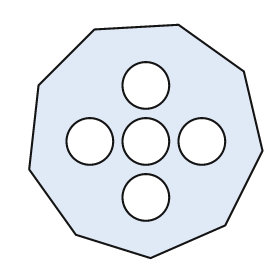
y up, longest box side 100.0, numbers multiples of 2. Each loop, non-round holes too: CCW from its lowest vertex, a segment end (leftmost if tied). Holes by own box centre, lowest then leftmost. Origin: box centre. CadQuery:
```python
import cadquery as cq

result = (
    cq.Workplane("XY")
    .moveTo(2.0, -50.0)
    .lineTo(34.0, -36.0)
    .lineTo(50.0, -4.0)
    .lineTo(42.0, 30.0)
    .lineTo(14.0, 50.0)
    .lineTo(-22.0, 48.0)
    .lineTo(-46.0, 24.0)
    .lineTo(-50.0, -12.0)
    .lineTo(-30.0, -40.0)
    .close()
    .moveTo(0.0, -24.0)
    .circle(10.0)
    .moveTo(-24.0, 0.0)
    .circle(10.0)
    .moveTo(0.0, 0.0)
    .circle(10.0)
    .moveTo(24.0, 0.0)
    .circle(10.0)
    .moveTo(0.0, 24.0)
    .circle(10.0)
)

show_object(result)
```